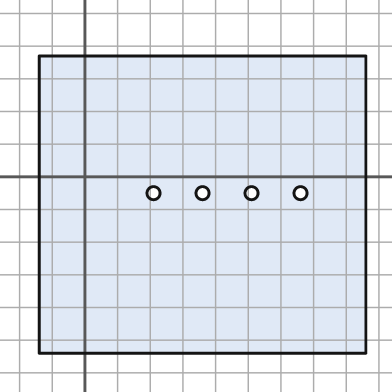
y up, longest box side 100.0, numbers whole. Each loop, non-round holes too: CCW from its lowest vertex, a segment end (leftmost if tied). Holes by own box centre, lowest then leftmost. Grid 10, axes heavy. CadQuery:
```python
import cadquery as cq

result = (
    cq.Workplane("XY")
    .moveTo(-14.0, -54.0)
    .lineTo(86.0, -54.0)
    .lineTo(86.0, 37.0)
    .lineTo(-14.0, 37.0)
    .close()
    .moveTo(21.0, -5.0)
    .circle(2.0)
    .moveTo(36.0, -5.0)
    .circle(2.0)
    .moveTo(51.0, -5.0)
    .circle(2.0)
    .moveTo(66.0, -5.0)
    .circle(2.0)
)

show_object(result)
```